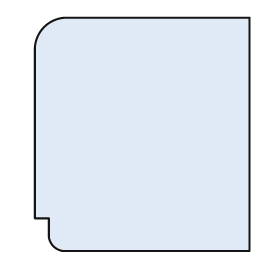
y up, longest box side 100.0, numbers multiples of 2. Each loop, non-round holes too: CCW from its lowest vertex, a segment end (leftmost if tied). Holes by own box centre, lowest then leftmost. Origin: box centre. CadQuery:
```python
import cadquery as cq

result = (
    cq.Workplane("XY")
    .moveTo(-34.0, -50.0)
    .lineTo(46.0, -50.0)
    .lineTo(46.0, 50.0)
    .lineTo(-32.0, 50.0)
    .threePointArc((-42.0, 46.0), (-46.0, 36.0))
    .lineTo(-46.0, -36.0)
    .lineTo(-40.0, -36.0)
    .lineTo(-40.0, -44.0)
    .threePointArc((-38.0, -48.0), (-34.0, -50.0))
    .close()
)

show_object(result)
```